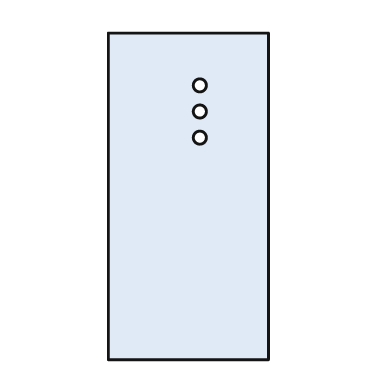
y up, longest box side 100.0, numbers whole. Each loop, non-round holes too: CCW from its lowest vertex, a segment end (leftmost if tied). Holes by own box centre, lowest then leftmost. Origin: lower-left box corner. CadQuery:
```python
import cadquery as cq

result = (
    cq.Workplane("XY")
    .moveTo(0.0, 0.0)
    .lineTo(49.0, 0.0)
    .lineTo(49.0, 100.0)
    .lineTo(0.0, 100.0)
    .close()
    .moveTo(28.0, 68.0)
    .circle(2.0)
    .moveTo(28.0, 76.0)
    .circle(2.0)
    .moveTo(28.0, 84.0)
    .circle(2.0)
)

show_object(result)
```